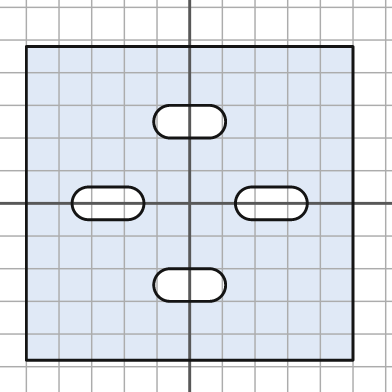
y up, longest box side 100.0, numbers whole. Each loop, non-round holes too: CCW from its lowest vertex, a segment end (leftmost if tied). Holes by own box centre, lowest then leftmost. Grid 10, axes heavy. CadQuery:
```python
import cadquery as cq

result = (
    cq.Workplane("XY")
    .moveTo(-50.0, -48.0)
    .lineTo(50.0, -48.0)
    .lineTo(50.0, 48.0)
    .lineTo(-50.0, 48.0)
    .close()
    .moveTo(-6.0, -30.0)
    .lineTo(6.0, -30.0)
    .threePointArc((11.0, -25.0), (6.0, -20.0))
    .lineTo(-6.0, -20.0)
    .threePointArc((-11.0, -25.0), (-6.0, -30.0))
    .close()
    .moveTo(-31.0, -5.0)
    .lineTo(-19.0, -5.0)
    .threePointArc((-14.0, 0.0), (-19.0, 5.0))
    .lineTo(-31.0, 5.0)
    .threePointArc((-36.0, 0.0), (-31.0, -5.0))
    .close()
    .moveTo(19.0, -5.0)
    .lineTo(31.0, -5.0)
    .threePointArc((36.0, 0.0), (31.0, 5.0))
    .lineTo(19.0, 5.0)
    .threePointArc((14.0, 0.0), (19.0, -5.0))
    .close()
    .moveTo(-6.0, 20.0)
    .lineTo(6.0, 20.0)
    .threePointArc((11.0, 25.0), (6.0, 30.0))
    .lineTo(-6.0, 30.0)
    .threePointArc((-11.0, 25.0), (-6.0, 20.0))
    .close()
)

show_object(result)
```